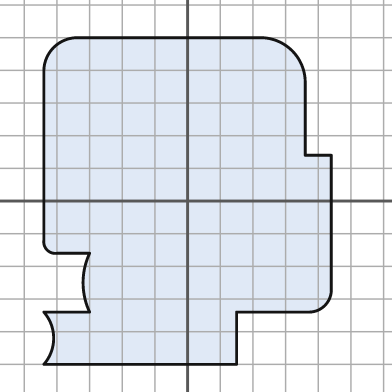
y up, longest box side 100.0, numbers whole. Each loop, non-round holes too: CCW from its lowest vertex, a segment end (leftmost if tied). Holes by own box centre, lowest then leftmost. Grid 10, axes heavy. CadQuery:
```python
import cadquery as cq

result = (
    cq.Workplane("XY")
    .moveTo(-44.0, -50.0)
    .lineTo(15.0, -50.0)
    .lineTo(15.0, -34.0)
    .lineTo(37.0, -34.0)
    .threePointArc((42.0, -32.0), (44.0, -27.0))
    .lineTo(44.0, 14.0)
    .lineTo(36.0, 14.0)
    .lineTo(36.0, 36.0)
    .threePointArc((32.0, 46.0), (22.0, 50.0))
    .lineTo(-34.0, 50.0)
    .threePointArc((-41.0, 47.0), (-44.0, 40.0))
    .lineTo(-44.0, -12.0)
    .threePointArc((-43.0, -15.0), (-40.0, -16.0))
    .lineTo(-30.0, -16.0)
    .threePointArc((-32.0, -25.0), (-30.0, -34.0))
    .lineTo(-44.0, -34.0)
    .threePointArc((-41.0, -42.0), (-44.0, -50.0))
    .close()
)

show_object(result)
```